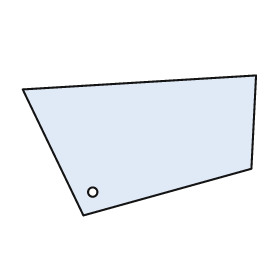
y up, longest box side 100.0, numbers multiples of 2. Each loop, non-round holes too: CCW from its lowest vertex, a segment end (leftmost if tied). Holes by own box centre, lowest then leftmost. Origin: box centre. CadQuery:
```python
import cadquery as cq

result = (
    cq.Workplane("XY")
    .moveTo(-24.0, -30.0)
    .lineTo(48.0, -10.0)
    .lineTo(50.0, 30.0)
    .lineTo(-50.0, 24.0)
    .close()
    .moveTo(-20.0, -20.0)
    .circle(2.0)
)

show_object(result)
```